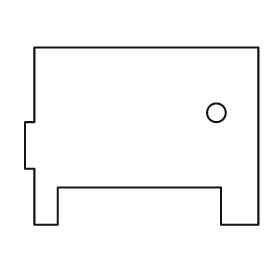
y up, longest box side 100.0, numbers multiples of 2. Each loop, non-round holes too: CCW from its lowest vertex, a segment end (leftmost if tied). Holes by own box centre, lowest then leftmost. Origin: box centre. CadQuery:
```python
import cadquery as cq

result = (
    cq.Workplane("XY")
    .moveTo(-46.0, -38.0)
    .lineTo(-36.0, -38.0)
    .lineTo(-36.0, -22.0)
    .lineTo(34.0, -22.0)
    .lineTo(34.0, -38.0)
    .lineTo(50.0, -38.0)
    .lineTo(50.0, 38.0)
    .lineTo(-46.0, 38.0)
    .lineTo(-46.0, 6.0)
    .lineTo(-50.0, 6.0)
    .lineTo(-50.0, -14.0)
    .lineTo(-46.0, -14.0)
    .close()
    .moveTo(32.0, 10.0)
    .circle(4.0)
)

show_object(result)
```